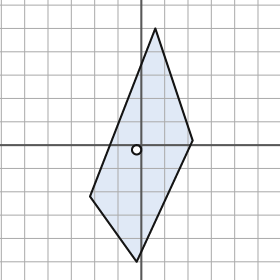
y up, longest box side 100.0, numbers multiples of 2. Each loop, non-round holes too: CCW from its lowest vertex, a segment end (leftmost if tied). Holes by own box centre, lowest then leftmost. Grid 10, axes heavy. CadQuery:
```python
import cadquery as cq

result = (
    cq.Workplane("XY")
    .moveTo(-2.0, -50.0)
    .lineTo(22.0, 2.0)
    .lineTo(6.0, 50.0)
    .lineTo(-22.0, -22.0)
    .close()
    .moveTo(-2.0, -2.0)
    .circle(2.0)
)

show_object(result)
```